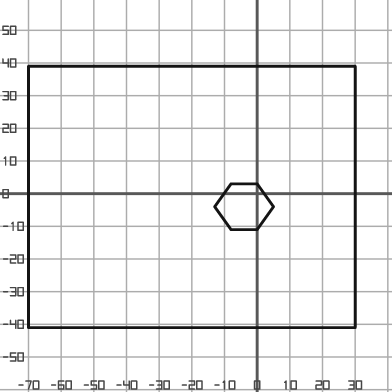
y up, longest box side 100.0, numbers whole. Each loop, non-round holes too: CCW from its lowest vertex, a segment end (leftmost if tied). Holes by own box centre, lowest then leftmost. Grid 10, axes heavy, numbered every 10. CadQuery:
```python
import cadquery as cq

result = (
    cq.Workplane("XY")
    .moveTo(-70.0, -41.0)
    .lineTo(30.0, -41.0)
    .lineTo(30.0, 39.0)
    .lineTo(-70.0, 39.0)
    .close()
    .moveTo(-8.0, -11.0)
    .lineTo(0.0, -11.0)
    .lineTo(5.0, -4.0)
    .lineTo(0.0, 3.0)
    .lineTo(-8.0, 3.0)
    .lineTo(-13.0, -4.0)
    .close()
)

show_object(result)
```